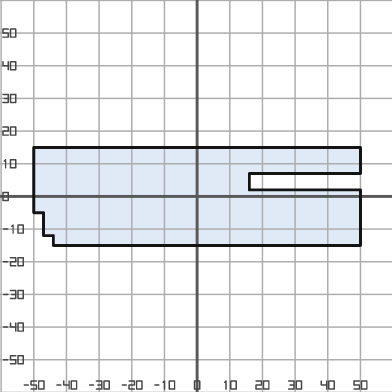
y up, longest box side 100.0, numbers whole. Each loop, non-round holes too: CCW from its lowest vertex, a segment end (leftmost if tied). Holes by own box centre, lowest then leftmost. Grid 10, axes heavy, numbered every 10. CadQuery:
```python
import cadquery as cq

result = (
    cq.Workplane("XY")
    .moveTo(-44.0, -15.0)
    .lineTo(50.0, -15.0)
    .lineTo(50.0, 2.0)
    .lineTo(16.0, 2.0)
    .lineTo(16.0, 7.0)
    .lineTo(50.0, 7.0)
    .lineTo(50.0, 15.0)
    .lineTo(-50.0, 15.0)
    .lineTo(-50.0, -5.0)
    .lineTo(-47.0, -5.0)
    .lineTo(-47.0, -12.0)
    .lineTo(-44.0, -12.0)
    .close()
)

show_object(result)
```